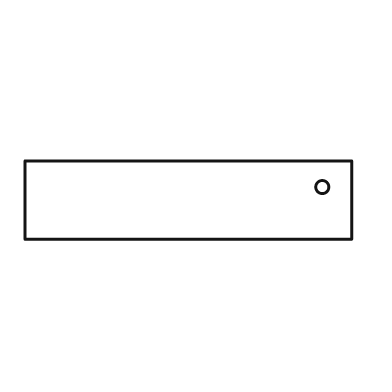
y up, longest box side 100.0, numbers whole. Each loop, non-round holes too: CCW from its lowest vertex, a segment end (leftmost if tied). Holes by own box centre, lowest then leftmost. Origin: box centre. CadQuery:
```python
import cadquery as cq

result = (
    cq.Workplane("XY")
    .moveTo(-50.0, -12.0)
    .lineTo(50.0, -12.0)
    .lineTo(50.0, 12.0)
    .lineTo(-50.0, 12.0)
    .close()
    .moveTo(41.0, 4.0)
    .circle(2.0)
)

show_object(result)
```